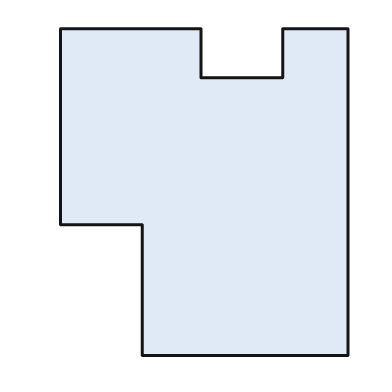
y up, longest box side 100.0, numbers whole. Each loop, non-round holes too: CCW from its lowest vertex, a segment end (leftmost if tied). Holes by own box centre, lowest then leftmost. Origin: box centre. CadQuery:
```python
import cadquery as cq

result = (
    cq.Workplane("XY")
    .moveTo(-19.0, -50.0)
    .lineTo(44.0, -50.0)
    .lineTo(44.0, 50.0)
    .lineTo(24.0, 50.0)
    .lineTo(24.0, 35.0)
    .lineTo(-1.0, 35.0)
    .lineTo(-1.0, 50.0)
    .lineTo(-44.0, 50.0)
    .lineTo(-44.0, -10.0)
    .lineTo(-19.0, -10.0)
    .close()
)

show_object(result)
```